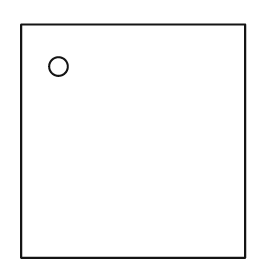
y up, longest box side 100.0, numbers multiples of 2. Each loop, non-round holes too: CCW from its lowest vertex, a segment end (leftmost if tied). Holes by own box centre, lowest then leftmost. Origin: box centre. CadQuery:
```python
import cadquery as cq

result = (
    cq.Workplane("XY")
    .moveTo(-48.0, -50.0)
    .lineTo(48.0, -50.0)
    .lineTo(48.0, 50.0)
    .lineTo(-48.0, 50.0)
    .close()
    .moveTo(-32.0, 32.0)
    .circle(4.0)
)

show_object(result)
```